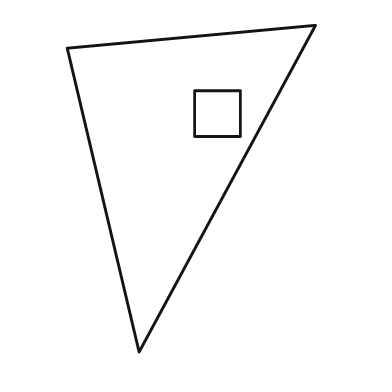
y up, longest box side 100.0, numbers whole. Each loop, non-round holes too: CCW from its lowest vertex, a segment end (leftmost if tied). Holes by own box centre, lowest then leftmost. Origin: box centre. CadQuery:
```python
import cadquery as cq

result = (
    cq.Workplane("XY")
    .moveTo(-16.0, -50.0)
    .lineTo(38.0, 50.0)
    .lineTo(-38.0, 43.0)
    .close()
    .moveTo(1.0, 16.0)
    .lineTo(15.0, 16.0)
    .lineTo(15.0, 30.0)
    .lineTo(1.0, 30.0)
    .close()
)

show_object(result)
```